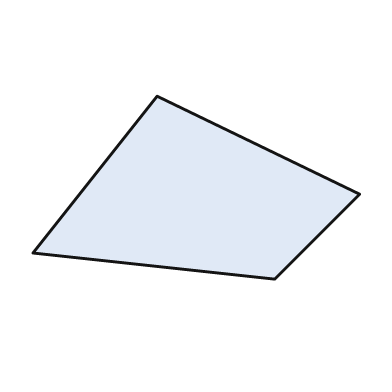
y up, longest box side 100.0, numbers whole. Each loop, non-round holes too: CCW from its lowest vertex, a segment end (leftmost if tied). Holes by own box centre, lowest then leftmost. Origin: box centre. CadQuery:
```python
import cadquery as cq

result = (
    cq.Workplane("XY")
    .moveTo(24.0, -28.0)
    .lineTo(50.0, -2.0)
    .lineTo(-12.0, 28.0)
    .lineTo(-50.0, -20.0)
    .close()
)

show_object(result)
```